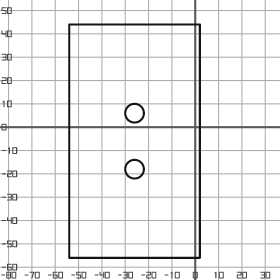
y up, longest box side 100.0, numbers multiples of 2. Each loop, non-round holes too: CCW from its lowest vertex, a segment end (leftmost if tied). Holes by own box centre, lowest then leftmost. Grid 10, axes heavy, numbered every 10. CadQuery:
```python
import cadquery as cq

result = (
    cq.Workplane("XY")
    .moveTo(-54.0, -56.0)
    .lineTo(2.0, -56.0)
    .lineTo(2.0, 44.0)
    .lineTo(-54.0, 44.0)
    .close()
    .moveTo(-26.0, -18.0)
    .circle(4.0)
    .moveTo(-26.0, 6.0)
    .circle(4.0)
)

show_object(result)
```